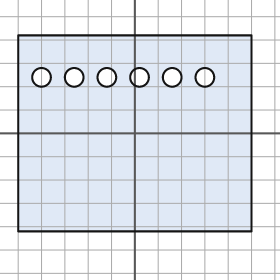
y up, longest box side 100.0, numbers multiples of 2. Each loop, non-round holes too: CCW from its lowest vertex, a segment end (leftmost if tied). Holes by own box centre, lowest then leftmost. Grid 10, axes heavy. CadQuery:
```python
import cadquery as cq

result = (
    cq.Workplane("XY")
    .moveTo(-50.0, -42.0)
    .lineTo(50.0, -42.0)
    .lineTo(50.0, 42.0)
    .lineTo(-50.0, 42.0)
    .close()
    .moveTo(-40.0, 24.0)
    .circle(4.0)
    .moveTo(-26.0, 24.0)
    .circle(4.0)
    .moveTo(-12.0, 24.0)
    .circle(4.0)
    .moveTo(2.0, 24.0)
    .circle(4.0)
    .moveTo(16.0, 24.0)
    .circle(4.0)
    .moveTo(30.0, 24.0)
    .circle(4.0)
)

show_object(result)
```